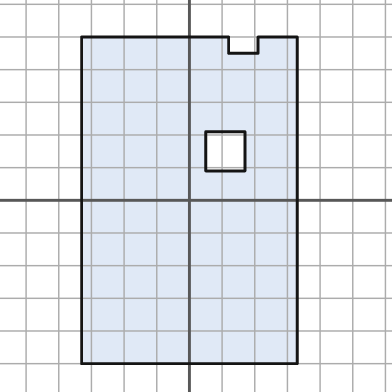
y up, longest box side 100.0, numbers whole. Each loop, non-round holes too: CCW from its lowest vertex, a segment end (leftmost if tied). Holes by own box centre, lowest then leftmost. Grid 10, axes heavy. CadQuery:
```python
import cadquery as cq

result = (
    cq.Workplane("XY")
    .moveTo(-33.0, -50.0)
    .lineTo(33.0, -50.0)
    .lineTo(33.0, 50.0)
    .lineTo(21.0, 50.0)
    .lineTo(21.0, 45.0)
    .lineTo(12.0, 45.0)
    .lineTo(12.0, 50.0)
    .lineTo(-33.0, 50.0)
    .close()
    .moveTo(5.0, 9.0)
    .lineTo(17.0, 9.0)
    .lineTo(17.0, 21.0)
    .lineTo(5.0, 21.0)
    .close()
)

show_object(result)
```